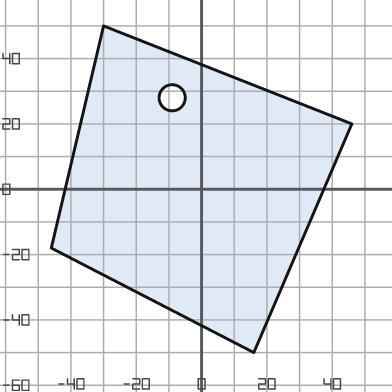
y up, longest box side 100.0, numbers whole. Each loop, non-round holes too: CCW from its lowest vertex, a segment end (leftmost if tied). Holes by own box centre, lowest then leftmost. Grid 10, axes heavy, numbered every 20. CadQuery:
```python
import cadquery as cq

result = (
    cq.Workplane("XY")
    .moveTo(16.0, -50.0)
    .lineTo(46.0, 20.0)
    .lineTo(-30.0, 50.0)
    .lineTo(-46.0, -18.0)
    .close()
    .moveTo(-9.0, 28.0)
    .circle(4.0)
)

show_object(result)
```